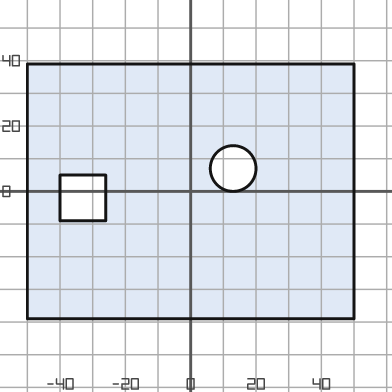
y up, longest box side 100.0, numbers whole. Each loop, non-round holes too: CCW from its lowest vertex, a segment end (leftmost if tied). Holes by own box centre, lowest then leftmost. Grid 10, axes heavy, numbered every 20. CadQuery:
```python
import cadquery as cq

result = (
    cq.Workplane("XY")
    .moveTo(-50.0, -39.0)
    .lineTo(50.0, -39.0)
    .lineTo(50.0, 39.0)
    .lineTo(-50.0, 39.0)
    .close()
    .moveTo(-40.0, -9.0)
    .lineTo(-26.0, -9.0)
    .lineTo(-26.0, 5.0)
    .lineTo(-40.0, 5.0)
    .close()
    .moveTo(13.0, 7.0)
    .circle(7.0)
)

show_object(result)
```